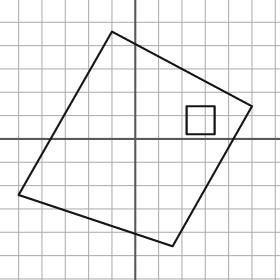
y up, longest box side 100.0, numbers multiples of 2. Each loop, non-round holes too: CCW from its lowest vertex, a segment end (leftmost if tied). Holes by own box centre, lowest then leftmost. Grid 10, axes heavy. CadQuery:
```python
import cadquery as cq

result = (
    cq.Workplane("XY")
    .moveTo(16.0, -46.0)
    .lineTo(50.0, 14.0)
    .lineTo(-10.0, 46.0)
    .lineTo(-50.0, -24.0)
    .close()
    .moveTo(22.0, 2.0)
    .lineTo(34.0, 2.0)
    .lineTo(34.0, 14.0)
    .lineTo(22.0, 14.0)
    .close()
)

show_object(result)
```